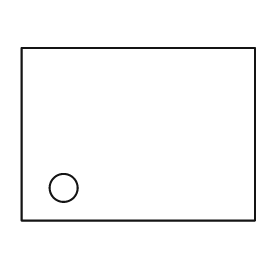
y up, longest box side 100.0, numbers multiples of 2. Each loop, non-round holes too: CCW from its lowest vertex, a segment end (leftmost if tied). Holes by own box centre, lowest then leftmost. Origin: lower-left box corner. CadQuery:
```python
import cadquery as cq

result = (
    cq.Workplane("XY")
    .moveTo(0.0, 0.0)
    .lineTo(100.0, 0.0)
    .lineTo(100.0, 74.0)
    .lineTo(0.0, 74.0)
    .close()
    .moveTo(18.0, 14.0)
    .circle(6.0)
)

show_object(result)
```